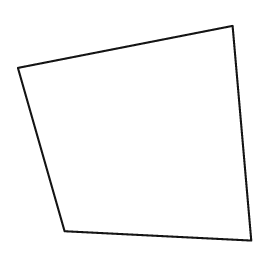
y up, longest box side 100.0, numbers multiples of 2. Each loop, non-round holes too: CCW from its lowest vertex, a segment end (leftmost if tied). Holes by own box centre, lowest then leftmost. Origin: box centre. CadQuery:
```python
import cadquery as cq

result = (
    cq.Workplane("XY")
    .moveTo(50.0, -46.0)
    .lineTo(42.0, 46.0)
    .lineTo(-50.0, 28.0)
    .lineTo(-30.0, -42.0)
    .close()
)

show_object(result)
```